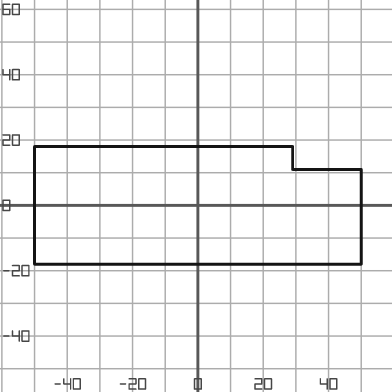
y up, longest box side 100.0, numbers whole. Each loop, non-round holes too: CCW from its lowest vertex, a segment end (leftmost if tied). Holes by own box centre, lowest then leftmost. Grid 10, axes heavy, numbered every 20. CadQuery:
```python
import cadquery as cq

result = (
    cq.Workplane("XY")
    .moveTo(-50.0, -18.0)
    .lineTo(50.0, -18.0)
    .lineTo(50.0, 11.0)
    .lineTo(29.0, 11.0)
    .lineTo(29.0, 18.0)
    .lineTo(-50.0, 18.0)
    .close()
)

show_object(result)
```